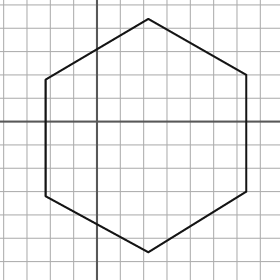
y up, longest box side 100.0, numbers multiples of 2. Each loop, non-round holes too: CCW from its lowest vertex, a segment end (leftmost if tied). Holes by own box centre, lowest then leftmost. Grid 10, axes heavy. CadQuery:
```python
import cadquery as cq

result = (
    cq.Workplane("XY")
    .moveTo(22.0, -56.0)
    .lineTo(64.0, -30.0)
    .lineTo(64.0, 20.0)
    .lineTo(22.0, 44.0)
    .lineTo(-22.0, 18.0)
    .lineTo(-22.0, -32.0)
    .close()
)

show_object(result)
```